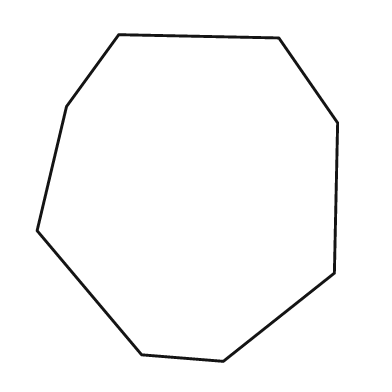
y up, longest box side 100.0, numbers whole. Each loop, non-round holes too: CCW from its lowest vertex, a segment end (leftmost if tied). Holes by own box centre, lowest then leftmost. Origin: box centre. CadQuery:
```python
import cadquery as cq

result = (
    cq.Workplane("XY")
    .moveTo(11.0, -50.0)
    .lineTo(45.0, -23.0)
    .lineTo(46.0, 23.0)
    .lineTo(28.0, 49.0)
    .lineTo(-21.0, 50.0)
    .lineTo(-37.0, 28.0)
    .lineTo(-46.0, -10.0)
    .lineTo(-14.0, -48.0)
    .close()
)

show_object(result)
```